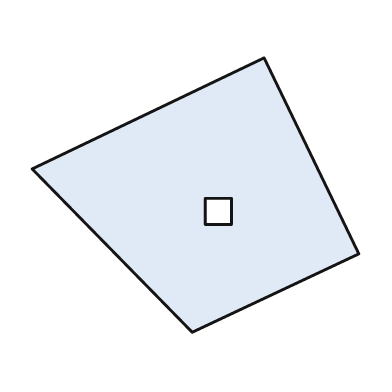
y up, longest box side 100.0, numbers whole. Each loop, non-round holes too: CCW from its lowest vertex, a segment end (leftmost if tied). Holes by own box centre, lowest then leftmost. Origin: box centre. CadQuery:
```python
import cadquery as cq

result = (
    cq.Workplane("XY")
    .moveTo(-1.0, -42.0)
    .lineTo(50.0, -18.0)
    .lineTo(21.0, 42.0)
    .lineTo(-50.0, 8.0)
    .close()
    .moveTo(3.0, -9.0)
    .lineTo(11.0, -9.0)
    .lineTo(11.0, -1.0)
    .lineTo(3.0, -1.0)
    .close()
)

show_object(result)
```